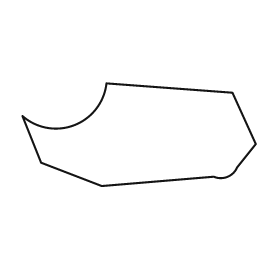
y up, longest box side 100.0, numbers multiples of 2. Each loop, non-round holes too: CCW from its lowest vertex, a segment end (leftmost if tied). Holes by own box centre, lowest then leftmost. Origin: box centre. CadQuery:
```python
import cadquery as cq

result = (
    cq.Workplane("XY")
    .moveTo(-16.0, -22.0)
    .lineTo(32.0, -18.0)
    .threePointArc((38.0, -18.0), (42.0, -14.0))
    .lineTo(50.0, -4.0)
    .lineTo(40.0, 18.0)
    .lineTo(-14.0, 22.0)
    .threePointArc((-28.0, 4.0), (-50.0, 8.0))
    .lineTo(-42.0, -12.0)
    .close()
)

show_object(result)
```